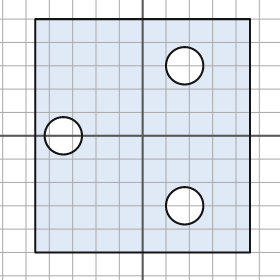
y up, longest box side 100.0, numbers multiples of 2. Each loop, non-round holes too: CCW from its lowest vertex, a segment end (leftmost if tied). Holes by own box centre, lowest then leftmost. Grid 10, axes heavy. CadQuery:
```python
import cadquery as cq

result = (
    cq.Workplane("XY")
    .moveTo(-46.0, -50.0)
    .lineTo(46.0, -50.0)
    .lineTo(46.0, 50.0)
    .lineTo(-46.0, 50.0)
    .close()
    .moveTo(18.0, -30.0)
    .circle(8.0)
    .moveTo(-34.0, 0.0)
    .circle(8.0)
    .moveTo(18.0, 30.0)
    .circle(8.0)
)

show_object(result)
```